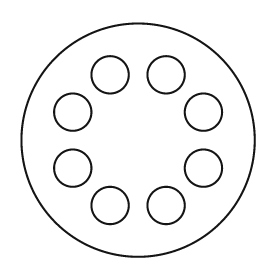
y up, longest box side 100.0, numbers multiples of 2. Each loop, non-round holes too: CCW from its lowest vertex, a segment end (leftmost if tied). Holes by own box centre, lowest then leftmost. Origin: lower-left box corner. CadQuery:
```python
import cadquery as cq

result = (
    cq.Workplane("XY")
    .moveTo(50.0, 50.0)
    .circle(50.0)
    .moveTo(38.0, 22.0)
    .circle(8.0)
    .moveTo(62.0, 22.0)
    .circle(8.0)
    .moveTo(22.0, 38.0)
    .circle(8.0)
    .moveTo(78.0, 38.0)
    .circle(8.0)
    .moveTo(22.0, 62.0)
    .circle(8.0)
    .moveTo(78.0, 62.0)
    .circle(8.0)
    .moveTo(38.0, 78.0)
    .circle(8.0)
    .moveTo(62.0, 78.0)
    .circle(8.0)
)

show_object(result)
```